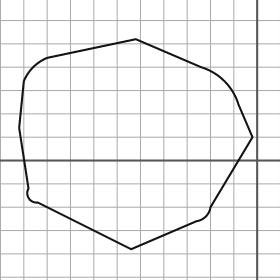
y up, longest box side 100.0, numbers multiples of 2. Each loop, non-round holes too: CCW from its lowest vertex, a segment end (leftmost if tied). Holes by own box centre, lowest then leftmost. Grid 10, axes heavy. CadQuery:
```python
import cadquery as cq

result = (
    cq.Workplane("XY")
    .moveTo(-54.0, -38.0)
    .lineTo(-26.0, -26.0)
    .threePointArc((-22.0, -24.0), (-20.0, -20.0))
    .lineTo(-2.0, 10.0)
    .lineTo(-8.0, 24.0)
    .threePointArc((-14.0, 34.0), (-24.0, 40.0))
    .lineTo(-52.0, 52.0)
    .lineTo(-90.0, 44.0)
    .threePointArc((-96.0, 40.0), (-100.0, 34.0))
    .lineTo(-102.0, 14.0)
    .lineTo(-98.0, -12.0)
    .threePointArc((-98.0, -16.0), (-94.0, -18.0))
    .close()
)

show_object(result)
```